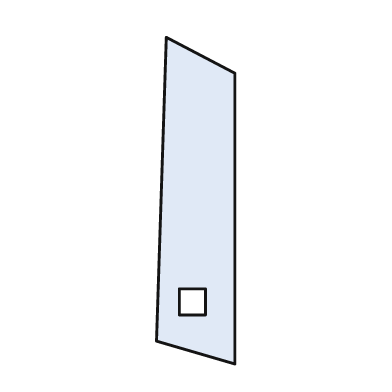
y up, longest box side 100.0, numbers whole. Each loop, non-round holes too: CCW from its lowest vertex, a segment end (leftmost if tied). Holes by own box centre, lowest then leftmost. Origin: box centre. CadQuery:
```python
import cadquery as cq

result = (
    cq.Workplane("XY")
    .moveTo(12.0, -50.0)
    .lineTo(12.0, 39.0)
    .lineTo(-9.0, 50.0)
    .lineTo(-12.0, -43.0)
    .close()
    .moveTo(-5.0, -35.0)
    .lineTo(3.0, -35.0)
    .lineTo(3.0, -27.0)
    .lineTo(-5.0, -27.0)
    .close()
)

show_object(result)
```